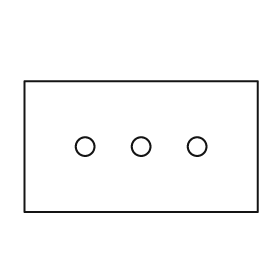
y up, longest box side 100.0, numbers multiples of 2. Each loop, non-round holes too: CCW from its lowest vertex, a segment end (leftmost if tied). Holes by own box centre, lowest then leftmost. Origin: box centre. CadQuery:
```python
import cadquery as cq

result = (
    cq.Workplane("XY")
    .moveTo(-50.0, -28.0)
    .lineTo(50.0, -28.0)
    .lineTo(50.0, 28.0)
    .lineTo(-50.0, 28.0)
    .close()
    .moveTo(-24.0, 0.0)
    .circle(4.0)
    .moveTo(0.0, 0.0)
    .circle(4.0)
    .moveTo(24.0, 0.0)
    .circle(4.0)
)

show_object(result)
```